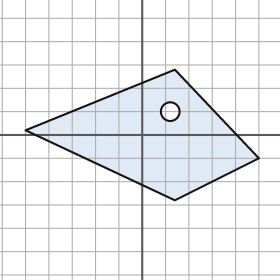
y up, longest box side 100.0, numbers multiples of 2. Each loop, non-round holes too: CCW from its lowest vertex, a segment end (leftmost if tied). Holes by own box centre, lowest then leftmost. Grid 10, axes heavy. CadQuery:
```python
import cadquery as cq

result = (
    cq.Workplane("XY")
    .moveTo(14.0, -28.0)
    .lineTo(50.0, -10.0)
    .lineTo(14.0, 28.0)
    .lineTo(-50.0, 2.0)
    .close()
    .moveTo(12.0, 10.0)
    .circle(4.0)
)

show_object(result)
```